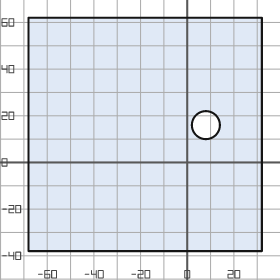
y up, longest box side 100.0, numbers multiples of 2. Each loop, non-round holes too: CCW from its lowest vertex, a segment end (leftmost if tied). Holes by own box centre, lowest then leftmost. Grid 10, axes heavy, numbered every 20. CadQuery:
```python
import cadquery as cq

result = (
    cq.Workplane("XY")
    .moveTo(-68.0, -38.0)
    .lineTo(32.0, -38.0)
    .lineTo(32.0, 62.0)
    .lineTo(-68.0, 62.0)
    .close()
    .moveTo(8.0, 16.0)
    .circle(6.0)
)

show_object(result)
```